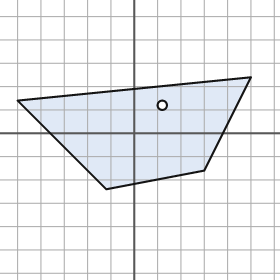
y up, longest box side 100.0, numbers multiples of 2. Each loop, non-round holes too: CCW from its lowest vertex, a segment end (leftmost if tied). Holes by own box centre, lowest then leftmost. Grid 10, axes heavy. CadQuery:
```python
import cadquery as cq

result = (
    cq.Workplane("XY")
    .moveTo(-12.0, -24.0)
    .lineTo(30.0, -16.0)
    .lineTo(50.0, 24.0)
    .lineTo(-50.0, 14.0)
    .close()
    .moveTo(12.0, 12.0)
    .circle(2.0)
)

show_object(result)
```